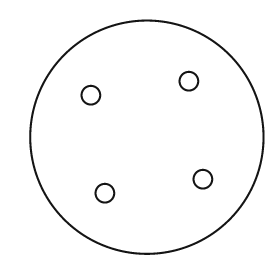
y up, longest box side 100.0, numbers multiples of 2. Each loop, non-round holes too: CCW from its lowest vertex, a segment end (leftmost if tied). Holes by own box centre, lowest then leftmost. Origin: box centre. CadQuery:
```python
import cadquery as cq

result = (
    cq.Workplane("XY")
    .moveTo(0.0, 0.0)
    .circle(50.0)
    .moveTo(-18.0, -24.0)
    .circle(4.0)
    .moveTo(24.0, -18.0)
    .circle(4.0)
    .moveTo(-24.0, 18.0)
    .circle(4.0)
    .moveTo(18.0, 24.0)
    .circle(4.0)
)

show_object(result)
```